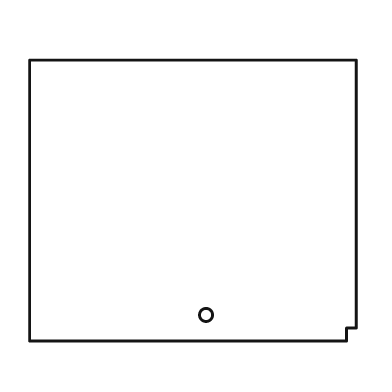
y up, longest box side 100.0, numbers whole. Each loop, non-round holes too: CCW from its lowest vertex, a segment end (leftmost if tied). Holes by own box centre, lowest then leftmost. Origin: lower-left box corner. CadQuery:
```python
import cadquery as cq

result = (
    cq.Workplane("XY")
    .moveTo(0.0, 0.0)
    .lineTo(97.0, 0.0)
    .lineTo(97.0, 4.0)
    .lineTo(100.0, 4.0)
    .lineTo(100.0, 86.0)
    .lineTo(0.0, 86.0)
    .close()
    .moveTo(54.0, 8.0)
    .circle(2.0)
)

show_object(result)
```